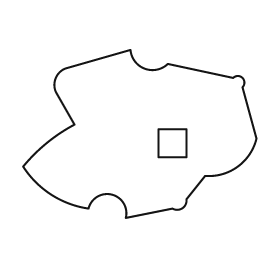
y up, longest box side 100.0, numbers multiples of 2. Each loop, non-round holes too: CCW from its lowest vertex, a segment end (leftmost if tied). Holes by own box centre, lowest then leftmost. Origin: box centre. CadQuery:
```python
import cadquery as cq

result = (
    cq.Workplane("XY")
    .moveTo(-6.0, -36.0)
    .lineTo(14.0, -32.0)
    .threePointArc((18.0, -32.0), (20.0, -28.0))
    .lineTo(28.0, -18.0)
    .threePointArc((42.0, -14.0), (50.0, -2.0))
    .lineTo(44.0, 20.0)
    .threePointArc((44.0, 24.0), (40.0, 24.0))
    .lineTo(12.0, 30.0)
    .threePointArc((2.0, 28.0), (-4.0, 36.0))
    .lineTo(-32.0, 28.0)
    .threePointArc((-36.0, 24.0), (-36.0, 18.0))
    .lineTo(-28.0, 4.0)
    .threePointArc((-40.0, -4.0), (-50.0, -14.0))
    .threePointArc((-38.0, -26.0), (-22.0, -32.0))
    .threePointArc((-12.0, -26.0), (-6.0, -36.0))
    .close()
    .moveTo(8.0, -10.0)
    .lineTo(20.0, -10.0)
    .lineTo(20.0, 2.0)
    .lineTo(8.0, 2.0)
    .close()
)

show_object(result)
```